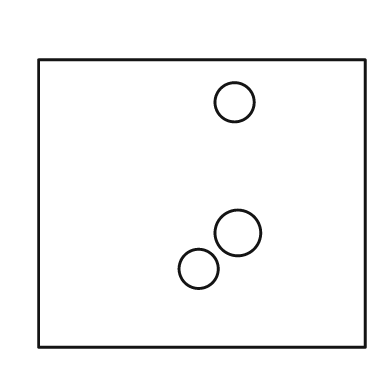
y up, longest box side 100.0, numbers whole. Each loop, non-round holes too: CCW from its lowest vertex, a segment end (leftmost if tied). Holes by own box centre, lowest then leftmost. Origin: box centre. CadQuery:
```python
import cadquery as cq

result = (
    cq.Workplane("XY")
    .moveTo(-50.0, -44.0)
    .lineTo(50.0, -44.0)
    .lineTo(50.0, 44.0)
    .lineTo(-50.0, 44.0)
    .close()
    .moveTo(-1.0, -20.0)
    .circle(6.0)
    .moveTo(11.0, -9.0)
    .circle(7.0)
    .moveTo(10.0, 31.0)
    .circle(6.0)
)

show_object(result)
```